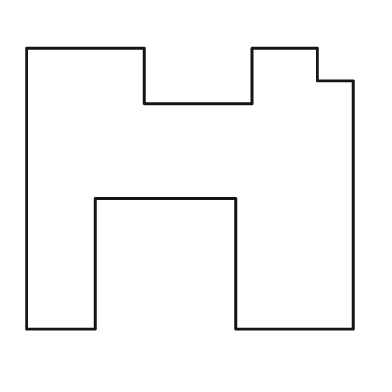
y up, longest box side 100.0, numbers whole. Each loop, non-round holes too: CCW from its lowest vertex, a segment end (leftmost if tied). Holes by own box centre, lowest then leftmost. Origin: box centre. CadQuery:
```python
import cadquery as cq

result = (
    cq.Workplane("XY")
    .moveTo(-50.0, -43.0)
    .lineTo(-29.0, -43.0)
    .lineTo(-29.0, -3.0)
    .lineTo(14.0, -3.0)
    .lineTo(14.0, -43.0)
    .lineTo(50.0, -43.0)
    .lineTo(50.0, 33.0)
    .lineTo(39.0, 33.0)
    .lineTo(39.0, 43.0)
    .lineTo(19.0, 43.0)
    .lineTo(19.0, 26.0)
    .lineTo(-14.0, 26.0)
    .lineTo(-14.0, 43.0)
    .lineTo(-50.0, 43.0)
    .close()
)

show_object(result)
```